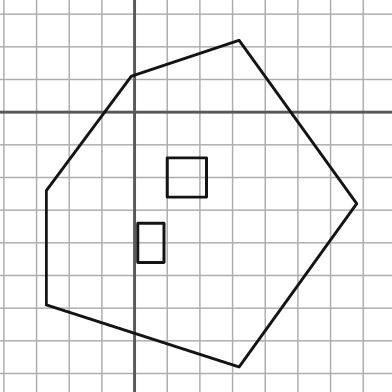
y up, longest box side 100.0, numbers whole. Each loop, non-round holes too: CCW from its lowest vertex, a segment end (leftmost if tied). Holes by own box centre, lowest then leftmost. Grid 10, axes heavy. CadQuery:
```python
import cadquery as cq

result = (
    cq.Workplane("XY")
    .moveTo(32.0, -78.0)
    .lineTo(68.0, -28.0)
    .lineTo(32.0, 22.0)
    .lineTo(-1.0, 11.0)
    .lineTo(-27.0, -24.0)
    .lineTo(-27.0, -59.0)
    .close()
    .moveTo(1.0, -46.0)
    .lineTo(9.0, -46.0)
    .lineTo(9.0, -34.0)
    .lineTo(1.0, -34.0)
    .close()
    .moveTo(10.0, -26.0)
    .lineTo(22.0, -26.0)
    .lineTo(22.0, -14.0)
    .lineTo(10.0, -14.0)
    .close()
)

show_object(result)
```